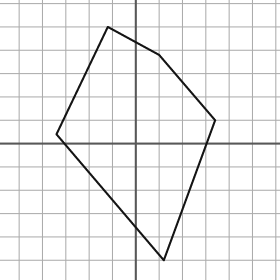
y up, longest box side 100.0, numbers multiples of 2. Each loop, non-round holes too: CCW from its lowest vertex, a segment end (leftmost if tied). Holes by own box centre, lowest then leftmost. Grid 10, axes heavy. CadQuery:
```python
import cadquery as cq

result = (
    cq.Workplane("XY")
    .moveTo(12.0, -50.0)
    .lineTo(34.0, 10.0)
    .lineTo(10.0, 38.0)
    .lineTo(-12.0, 50.0)
    .lineTo(-34.0, 4.0)
    .close()
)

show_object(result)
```